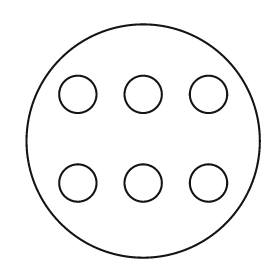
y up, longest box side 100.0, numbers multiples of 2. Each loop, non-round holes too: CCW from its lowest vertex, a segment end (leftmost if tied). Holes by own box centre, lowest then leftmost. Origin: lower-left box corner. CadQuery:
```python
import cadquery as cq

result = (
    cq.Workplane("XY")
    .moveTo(50.0, 50.0)
    .circle(50.0)
    .moveTo(22.0, 32.0)
    .circle(8.0)
    .moveTo(50.0, 32.0)
    .circle(8.0)
    .moveTo(78.0, 32.0)
    .circle(8.0)
    .moveTo(22.0, 70.0)
    .circle(8.0)
    .moveTo(50.0, 70.0)
    .circle(8.0)
    .moveTo(78.0, 70.0)
    .circle(8.0)
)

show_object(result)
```